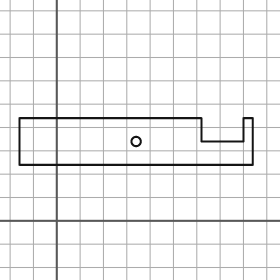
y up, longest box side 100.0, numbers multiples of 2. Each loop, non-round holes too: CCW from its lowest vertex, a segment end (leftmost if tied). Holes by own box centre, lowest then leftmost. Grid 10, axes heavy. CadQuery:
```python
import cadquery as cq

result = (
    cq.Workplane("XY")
    .moveTo(-16.0, 24.0)
    .lineTo(84.0, 24.0)
    .lineTo(84.0, 44.0)
    .lineTo(80.0, 44.0)
    .lineTo(80.0, 34.0)
    .lineTo(62.0, 34.0)
    .lineTo(62.0, 44.0)
    .lineTo(-16.0, 44.0)
    .close()
    .moveTo(34.0, 34.0)
    .circle(2.0)
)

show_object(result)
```